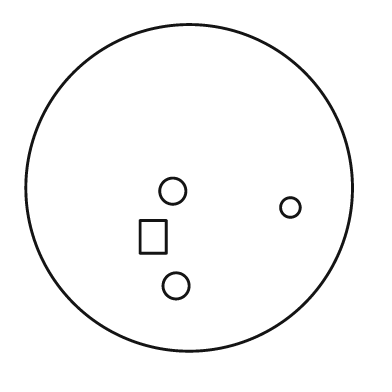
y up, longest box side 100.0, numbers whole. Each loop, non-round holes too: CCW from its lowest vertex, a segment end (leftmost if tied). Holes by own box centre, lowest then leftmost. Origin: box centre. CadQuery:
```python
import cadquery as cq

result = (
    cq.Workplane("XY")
    .moveTo(0.0, 0.0)
    .circle(50.0)
    .moveTo(-4.0, -30.0)
    .circle(4.0)
    .moveTo(-15.0, -20.0)
    .lineTo(-7.0, -20.0)
    .lineTo(-7.0, -10.0)
    .lineTo(-15.0, -10.0)
    .close()
    .moveTo(31.0, -6.0)
    .circle(3.0)
    .moveTo(-5.0, -1.0)
    .circle(4.0)
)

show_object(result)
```